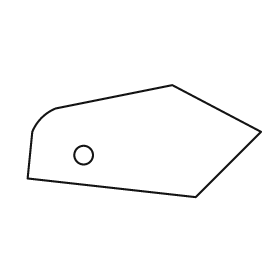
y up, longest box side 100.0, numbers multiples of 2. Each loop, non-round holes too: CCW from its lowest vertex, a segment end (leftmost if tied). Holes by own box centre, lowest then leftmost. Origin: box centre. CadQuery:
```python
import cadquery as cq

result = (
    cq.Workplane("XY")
    .moveTo(22.0, -24.0)
    .lineTo(50.0, 4.0)
    .lineTo(12.0, 24.0)
    .lineTo(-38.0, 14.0)
    .threePointArc((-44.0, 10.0), (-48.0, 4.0))
    .lineTo(-50.0, -16.0)
    .close()
    .moveTo(-26.0, -6.0)
    .circle(4.0)
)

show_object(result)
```